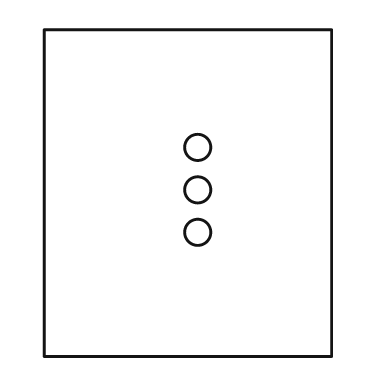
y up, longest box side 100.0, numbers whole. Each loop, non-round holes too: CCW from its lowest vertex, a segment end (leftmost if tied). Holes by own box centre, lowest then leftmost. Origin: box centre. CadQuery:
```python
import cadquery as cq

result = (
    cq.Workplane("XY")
    .moveTo(-44.0, -50.0)
    .lineTo(44.0, -50.0)
    .lineTo(44.0, 50.0)
    .lineTo(-44.0, 50.0)
    .close()
    .moveTo(3.0, -12.0)
    .circle(4.0)
    .moveTo(3.0, 1.0)
    .circle(4.0)
    .moveTo(3.0, 14.0)
    .circle(4.0)
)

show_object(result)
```